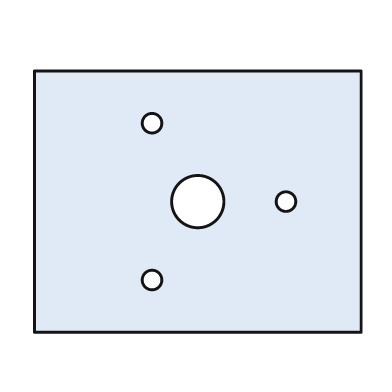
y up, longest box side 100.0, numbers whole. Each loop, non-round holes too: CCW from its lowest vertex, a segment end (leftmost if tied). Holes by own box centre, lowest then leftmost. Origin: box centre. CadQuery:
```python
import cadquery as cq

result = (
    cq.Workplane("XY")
    .moveTo(-50.0, -40.0)
    .lineTo(50.0, -40.0)
    .lineTo(50.0, 40.0)
    .lineTo(-50.0, 40.0)
    .close()
    .moveTo(-14.0, -24.0)
    .circle(3.0)
    .moveTo(0.0, 0.0)
    .circle(8.0)
    .moveTo(27.0, 0.0)
    .circle(3.0)
    .moveTo(-14.0, 24.0)
    .circle(3.0)
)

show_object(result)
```